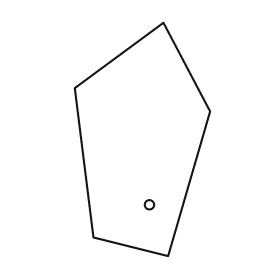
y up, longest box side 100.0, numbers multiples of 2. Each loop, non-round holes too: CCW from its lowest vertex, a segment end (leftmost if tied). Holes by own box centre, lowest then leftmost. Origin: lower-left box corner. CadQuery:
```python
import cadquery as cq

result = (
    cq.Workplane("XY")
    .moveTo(40.0, 0.0)
    .lineTo(58.0, 62.0)
    .lineTo(38.0, 100.0)
    .lineTo(0.0, 72.0)
    .lineTo(8.0, 8.0)
    .close()
    .moveTo(32.0, 22.0)
    .circle(2.0)
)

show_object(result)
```